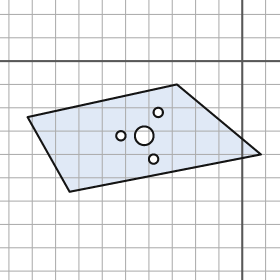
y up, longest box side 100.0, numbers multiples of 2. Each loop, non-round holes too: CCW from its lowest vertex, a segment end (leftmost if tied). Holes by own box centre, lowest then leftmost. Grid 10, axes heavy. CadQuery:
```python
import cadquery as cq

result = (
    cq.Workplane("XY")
    .moveTo(-74.0, -56.0)
    .lineTo(8.0, -40.0)
    .lineTo(-28.0, -10.0)
    .lineTo(-92.0, -24.0)
    .close()
    .moveTo(-38.0, -42.0)
    .circle(2.0)
    .moveTo(-52.0, -32.0)
    .circle(2.0)
    .moveTo(-42.0, -32.0)
    .circle(4.0)
    .moveTo(-36.0, -22.0)
    .circle(2.0)
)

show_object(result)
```